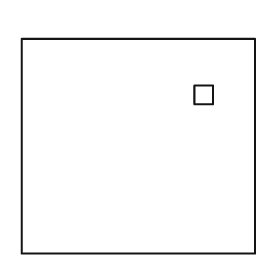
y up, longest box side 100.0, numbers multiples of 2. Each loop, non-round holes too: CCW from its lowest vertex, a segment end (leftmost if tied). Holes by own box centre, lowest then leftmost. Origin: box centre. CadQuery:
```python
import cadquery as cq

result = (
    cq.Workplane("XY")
    .moveTo(-50.0, -46.0)
    .lineTo(50.0, -46.0)
    .lineTo(50.0, 46.0)
    .lineTo(-50.0, 46.0)
    .close()
    .moveTo(24.0, 18.0)
    .lineTo(32.0, 18.0)
    .lineTo(32.0, 26.0)
    .lineTo(24.0, 26.0)
    .close()
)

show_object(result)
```